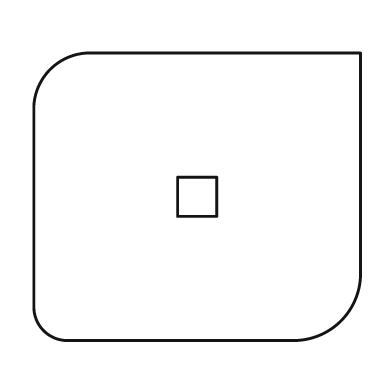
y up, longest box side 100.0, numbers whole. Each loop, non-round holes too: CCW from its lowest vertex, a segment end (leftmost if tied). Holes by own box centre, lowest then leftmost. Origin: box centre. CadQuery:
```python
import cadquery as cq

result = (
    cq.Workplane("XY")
    .moveTo(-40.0, -44.0)
    .lineTo(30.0, -44.0)
    .threePointArc((44.0, -38.0), (50.0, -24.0))
    .lineTo(50.0, 44.0)
    .lineTo(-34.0, 44.0)
    .threePointArc((-45.0, 39.0), (-50.0, 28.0))
    .lineTo(-50.0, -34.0)
    .threePointArc((-47.0, -41.0), (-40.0, -44.0))
    .close()
    .moveTo(-6.0, -6.0)
    .lineTo(6.0, -6.0)
    .lineTo(6.0, 6.0)
    .lineTo(-6.0, 6.0)
    .close()
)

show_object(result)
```